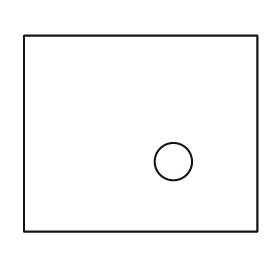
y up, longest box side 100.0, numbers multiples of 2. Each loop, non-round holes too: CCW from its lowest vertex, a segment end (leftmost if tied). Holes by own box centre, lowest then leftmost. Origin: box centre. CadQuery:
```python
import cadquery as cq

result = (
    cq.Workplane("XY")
    .moveTo(-50.0, -42.0)
    .lineTo(50.0, -42.0)
    .lineTo(50.0, 42.0)
    .lineTo(-50.0, 42.0)
    .close()
    .moveTo(14.0, -12.0)
    .circle(8.0)
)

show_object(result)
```